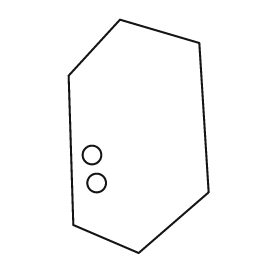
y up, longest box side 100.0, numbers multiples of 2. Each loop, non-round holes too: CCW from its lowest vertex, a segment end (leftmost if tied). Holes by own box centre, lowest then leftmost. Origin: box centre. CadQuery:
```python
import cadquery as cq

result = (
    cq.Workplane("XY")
    .moveTo(0.0, -50.0)
    .lineTo(30.0, -24.0)
    .lineTo(26.0, 40.0)
    .lineTo(-8.0, 50.0)
    .lineTo(-30.0, 26.0)
    .lineTo(-28.0, -38.0)
    .close()
    .moveTo(-18.0, -20.0)
    .circle(4.0)
    .moveTo(-20.0, -8.0)
    .circle(4.0)
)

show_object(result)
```